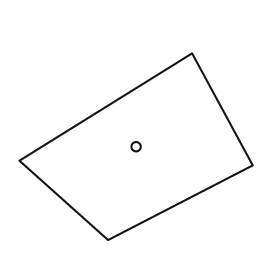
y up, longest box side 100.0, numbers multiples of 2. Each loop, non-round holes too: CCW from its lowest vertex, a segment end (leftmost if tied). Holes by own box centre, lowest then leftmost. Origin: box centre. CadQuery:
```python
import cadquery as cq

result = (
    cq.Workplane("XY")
    .moveTo(-12.0, -40.0)
    .lineTo(50.0, -8.0)
    .lineTo(24.0, 40.0)
    .lineTo(-50.0, -6.0)
    .close()
    .moveTo(0.0, 0.0)
    .circle(2.0)
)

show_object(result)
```